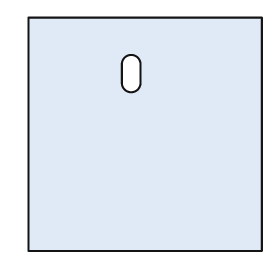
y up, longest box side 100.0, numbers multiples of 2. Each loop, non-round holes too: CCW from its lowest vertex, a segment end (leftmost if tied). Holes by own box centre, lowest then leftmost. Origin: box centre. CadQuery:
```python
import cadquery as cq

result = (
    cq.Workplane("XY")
    .moveTo(-50.0, -50.0)
    .lineTo(50.0, -50.0)
    .lineTo(50.0, 50.0)
    .lineTo(-50.0, 50.0)
    .close()
    .moveTo(-10.0, 22.0)
    .threePointArc((-6.0, 18.0), (-2.0, 22.0))
    .lineTo(-2.0, 30.0)
    .threePointArc((-6.0, 34.0), (-10.0, 30.0))
    .close()
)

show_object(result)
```